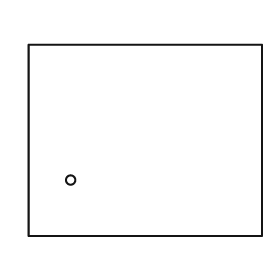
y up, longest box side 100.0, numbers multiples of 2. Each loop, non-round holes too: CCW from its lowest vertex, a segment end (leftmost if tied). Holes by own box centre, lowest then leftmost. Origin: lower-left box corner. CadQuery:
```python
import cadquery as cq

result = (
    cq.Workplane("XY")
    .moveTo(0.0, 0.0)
    .lineTo(100.0, 0.0)
    .lineTo(100.0, 82.0)
    .lineTo(0.0, 82.0)
    .close()
    .moveTo(18.0, 24.0)
    .circle(2.0)
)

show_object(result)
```